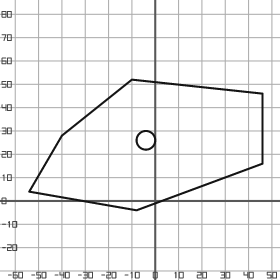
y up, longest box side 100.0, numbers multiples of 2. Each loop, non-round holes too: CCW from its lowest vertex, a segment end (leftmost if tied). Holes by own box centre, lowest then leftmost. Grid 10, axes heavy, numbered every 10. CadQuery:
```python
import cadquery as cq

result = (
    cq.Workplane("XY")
    .moveTo(-8.0, -4.0)
    .lineTo(46.0, 16.0)
    .lineTo(46.0, 46.0)
    .lineTo(-10.0, 52.0)
    .lineTo(-40.0, 28.0)
    .lineTo(-54.0, 4.0)
    .close()
    .moveTo(-4.0, 26.0)
    .circle(4.0)
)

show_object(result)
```